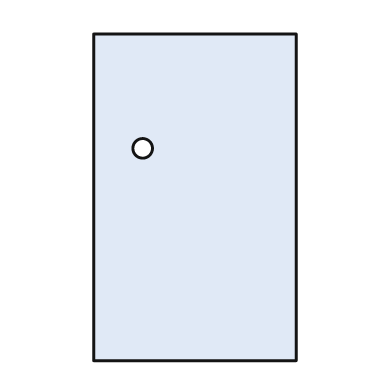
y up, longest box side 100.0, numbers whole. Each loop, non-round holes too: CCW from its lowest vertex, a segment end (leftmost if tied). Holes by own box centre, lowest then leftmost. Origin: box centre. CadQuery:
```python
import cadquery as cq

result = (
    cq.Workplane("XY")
    .moveTo(-31.0, -50.0)
    .lineTo(31.0, -50.0)
    .lineTo(31.0, 50.0)
    .lineTo(-31.0, 50.0)
    .close()
    .moveTo(-16.0, 15.0)
    .circle(3.0)
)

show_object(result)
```